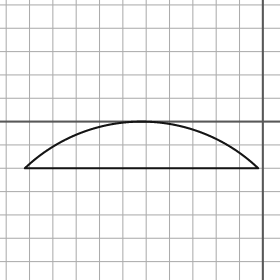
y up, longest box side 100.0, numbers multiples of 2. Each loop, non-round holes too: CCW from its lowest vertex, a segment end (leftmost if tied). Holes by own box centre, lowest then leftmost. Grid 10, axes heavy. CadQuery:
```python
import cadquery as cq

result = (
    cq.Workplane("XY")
    .moveTo(-102.0, -20.0)
    .lineTo(-2.0, -20.0)
    .threePointArc((-52.0, 0.0), (-102.0, -20.0))
    .close()
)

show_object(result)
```